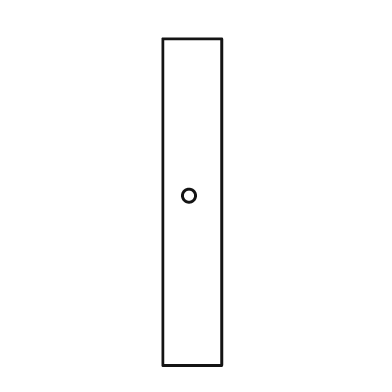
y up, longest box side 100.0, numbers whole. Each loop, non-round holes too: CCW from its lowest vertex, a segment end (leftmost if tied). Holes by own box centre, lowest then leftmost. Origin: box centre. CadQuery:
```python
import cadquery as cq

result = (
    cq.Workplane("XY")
    .moveTo(-9.0, -50.0)
    .lineTo(9.0, -50.0)
    .lineTo(9.0, 50.0)
    .lineTo(-9.0, 50.0)
    .close()
    .moveTo(-1.0, 2.0)
    .circle(2.0)
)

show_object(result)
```